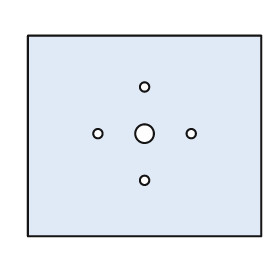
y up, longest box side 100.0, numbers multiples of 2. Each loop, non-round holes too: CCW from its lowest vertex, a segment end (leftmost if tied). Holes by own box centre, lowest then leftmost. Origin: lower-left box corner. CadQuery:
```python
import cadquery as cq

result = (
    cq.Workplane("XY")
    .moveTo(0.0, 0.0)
    .lineTo(100.0, 0.0)
    .lineTo(100.0, 86.0)
    .lineTo(0.0, 86.0)
    .close()
    .moveTo(50.0, 24.0)
    .circle(2.0)
    .moveTo(30.0, 44.0)
    .circle(2.0)
    .moveTo(50.0, 44.0)
    .circle(4.0)
    .moveTo(70.0, 44.0)
    .circle(2.0)
    .moveTo(50.0, 64.0)
    .circle(2.0)
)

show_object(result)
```